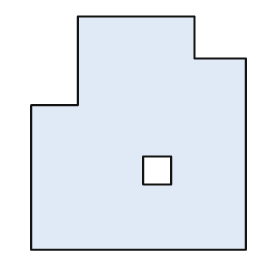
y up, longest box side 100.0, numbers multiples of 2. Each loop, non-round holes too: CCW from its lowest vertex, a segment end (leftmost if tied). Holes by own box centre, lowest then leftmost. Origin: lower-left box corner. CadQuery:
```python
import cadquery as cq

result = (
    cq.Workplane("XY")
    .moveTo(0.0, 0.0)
    .lineTo(92.0, 0.0)
    .lineTo(92.0, 82.0)
    .lineTo(70.0, 82.0)
    .lineTo(70.0, 100.0)
    .lineTo(20.0, 100.0)
    .lineTo(20.0, 62.0)
    .lineTo(0.0, 62.0)
    .close()
    .moveTo(48.0, 28.0)
    .lineTo(60.0, 28.0)
    .lineTo(60.0, 40.0)
    .lineTo(48.0, 40.0)
    .close()
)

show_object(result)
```